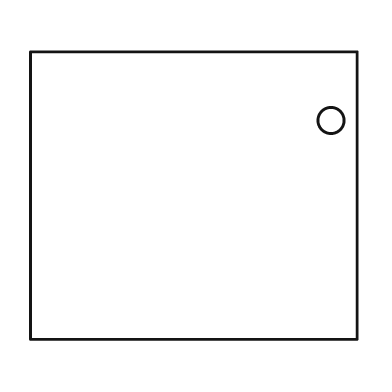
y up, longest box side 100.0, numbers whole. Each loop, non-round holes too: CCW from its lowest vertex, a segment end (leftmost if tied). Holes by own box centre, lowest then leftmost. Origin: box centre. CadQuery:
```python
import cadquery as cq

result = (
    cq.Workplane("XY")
    .moveTo(-50.0, -44.0)
    .lineTo(50.0, -44.0)
    .lineTo(50.0, 44.0)
    .lineTo(-50.0, 44.0)
    .close()
    .moveTo(42.0, 23.0)
    .circle(4.0)
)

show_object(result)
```